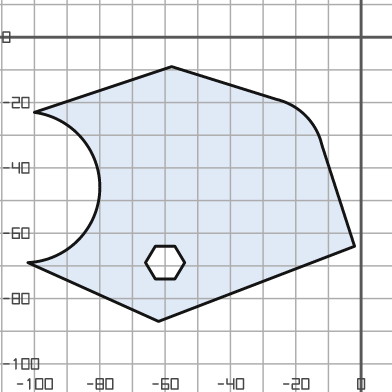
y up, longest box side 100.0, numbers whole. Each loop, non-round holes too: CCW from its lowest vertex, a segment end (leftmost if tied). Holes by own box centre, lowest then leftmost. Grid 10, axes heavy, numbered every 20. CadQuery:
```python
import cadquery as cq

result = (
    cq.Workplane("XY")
    .moveTo(-62.0, -87.0)
    .lineTo(-2.0, -64.0)
    .lineTo(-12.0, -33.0)
    .threePointArc((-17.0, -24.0), (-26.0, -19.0))
    .lineTo(-58.0, -9.0)
    .lineTo(-100.0, -23.0)
    .threePointArc((-80.0, -47.0), (-102.0, -69.0))
    .close()
    .moveTo(-63.0, -74.0)
    .lineTo(-57.0, -74.0)
    .lineTo(-54.0, -69.0)
    .lineTo(-57.0, -64.0)
    .lineTo(-63.0, -64.0)
    .lineTo(-66.0, -69.0)
    .close()
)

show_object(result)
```